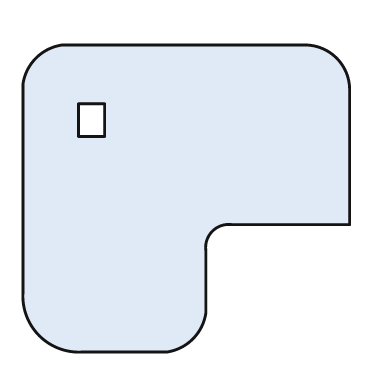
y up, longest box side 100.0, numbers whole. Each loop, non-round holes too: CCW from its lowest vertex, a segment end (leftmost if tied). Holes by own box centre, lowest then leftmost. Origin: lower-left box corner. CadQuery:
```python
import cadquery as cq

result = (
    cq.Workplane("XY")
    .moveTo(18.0, 0.0)
    .lineTo(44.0, 0.0)
    .threePointArc((52.0, 4.0), (56.0, 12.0))
    .lineTo(56.0, 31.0)
    .threePointArc((58.0, 37.0), (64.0, 39.0))
    .lineTo(100.0, 39.0)
    .lineTo(100.0, 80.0)
    .threePointArc((96.0, 90.0), (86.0, 94.0))
    .lineTo(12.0, 94.0)
    .threePointArc((4.0, 90.0), (0.0, 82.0))
    .lineTo(0.0, 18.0)
    .threePointArc((5.0, 5.0), (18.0, 0.0))
    .close()
    .moveTo(17.0, 66.0)
    .lineTo(25.0, 66.0)
    .lineTo(25.0, 76.0)
    .lineTo(17.0, 76.0)
    .close()
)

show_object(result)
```